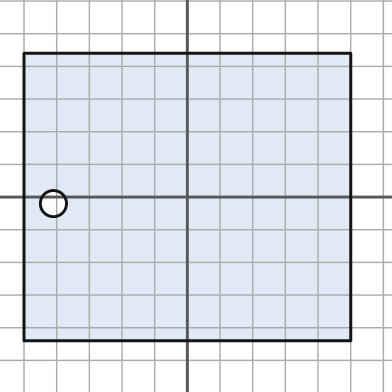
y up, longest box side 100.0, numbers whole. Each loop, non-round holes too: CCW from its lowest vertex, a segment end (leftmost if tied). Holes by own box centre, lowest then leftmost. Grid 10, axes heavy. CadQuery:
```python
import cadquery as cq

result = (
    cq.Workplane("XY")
    .moveTo(-50.0, -44.0)
    .lineTo(50.0, -44.0)
    .lineTo(50.0, 44.0)
    .lineTo(-50.0, 44.0)
    .close()
    .moveTo(-41.0, -2.0)
    .circle(4.0)
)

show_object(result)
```